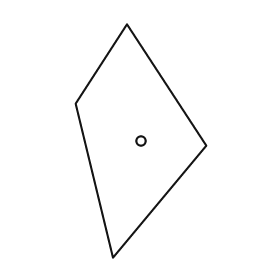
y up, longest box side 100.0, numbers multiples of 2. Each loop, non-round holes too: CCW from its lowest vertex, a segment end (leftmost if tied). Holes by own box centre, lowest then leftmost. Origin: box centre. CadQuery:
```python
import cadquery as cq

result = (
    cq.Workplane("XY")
    .moveTo(-12.0, -50.0)
    .lineTo(28.0, -2.0)
    .lineTo(-6.0, 50.0)
    .lineTo(-28.0, 16.0)
    .close()
    .moveTo(0.0, 0.0)
    .circle(2.0)
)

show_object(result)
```